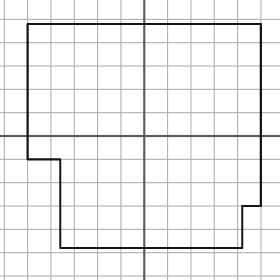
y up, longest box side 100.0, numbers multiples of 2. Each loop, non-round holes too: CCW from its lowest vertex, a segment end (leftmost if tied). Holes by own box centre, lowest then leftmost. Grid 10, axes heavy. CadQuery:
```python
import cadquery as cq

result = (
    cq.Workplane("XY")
    .moveTo(-36.0, -48.0)
    .lineTo(42.0, -48.0)
    .lineTo(42.0, -30.0)
    .lineTo(50.0, -30.0)
    .lineTo(50.0, 48.0)
    .lineTo(-50.0, 48.0)
    .lineTo(-50.0, -10.0)
    .lineTo(-36.0, -10.0)
    .close()
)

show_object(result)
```